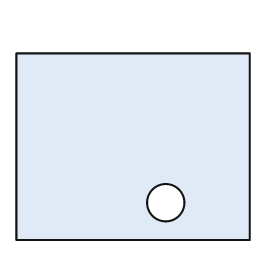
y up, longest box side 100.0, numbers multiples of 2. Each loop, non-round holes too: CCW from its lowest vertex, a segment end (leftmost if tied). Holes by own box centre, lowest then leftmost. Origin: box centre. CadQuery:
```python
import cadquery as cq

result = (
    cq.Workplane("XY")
    .moveTo(-50.0, -40.0)
    .lineTo(50.0, -40.0)
    .lineTo(50.0, 40.0)
    .lineTo(-50.0, 40.0)
    .close()
    .moveTo(14.0, -24.0)
    .circle(8.0)
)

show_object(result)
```